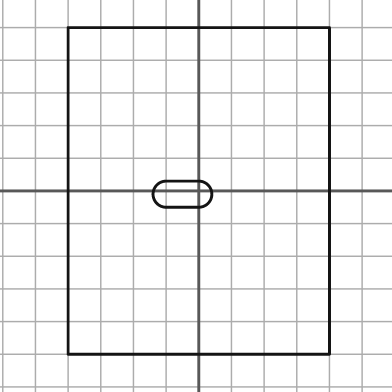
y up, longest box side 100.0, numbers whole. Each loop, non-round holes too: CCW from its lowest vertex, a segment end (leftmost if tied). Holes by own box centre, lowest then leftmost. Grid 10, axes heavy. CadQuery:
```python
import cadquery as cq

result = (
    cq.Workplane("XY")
    .moveTo(-40.0, -50.0)
    .lineTo(40.0, -50.0)
    .lineTo(40.0, 50.0)
    .lineTo(-40.0, 50.0)
    .close()
    .moveTo(-10.0, -5.0)
    .lineTo(0.0, -5.0)
    .threePointArc((4.0, -1.0), (0.0, 3.0))
    .lineTo(-10.0, 3.0)
    .threePointArc((-14.0, -1.0), (-10.0, -5.0))
    .close()
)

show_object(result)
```